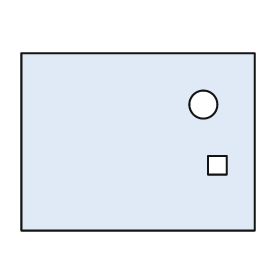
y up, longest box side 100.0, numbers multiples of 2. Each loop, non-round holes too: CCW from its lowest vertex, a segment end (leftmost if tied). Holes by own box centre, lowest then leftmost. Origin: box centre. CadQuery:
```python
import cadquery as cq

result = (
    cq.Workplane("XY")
    .moveTo(-50.0, -38.0)
    .lineTo(50.0, -38.0)
    .lineTo(50.0, 38.0)
    .lineTo(-50.0, 38.0)
    .close()
    .moveTo(30.0, -14.0)
    .lineTo(38.0, -14.0)
    .lineTo(38.0, -6.0)
    .lineTo(30.0, -6.0)
    .close()
    .moveTo(28.0, 16.0)
    .circle(6.0)
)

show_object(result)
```